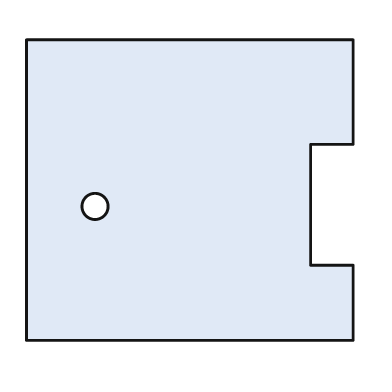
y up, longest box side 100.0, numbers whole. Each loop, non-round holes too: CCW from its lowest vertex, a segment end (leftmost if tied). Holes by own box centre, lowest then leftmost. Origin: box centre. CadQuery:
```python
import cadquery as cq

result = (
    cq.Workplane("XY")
    .moveTo(-50.0, -46.0)
    .lineTo(50.0, -46.0)
    .lineTo(50.0, -23.0)
    .lineTo(37.0, -23.0)
    .lineTo(37.0, 14.0)
    .lineTo(50.0, 14.0)
    .lineTo(50.0, 46.0)
    .lineTo(-50.0, 46.0)
    .close()
    .moveTo(-29.0, -5.0)
    .circle(4.0)
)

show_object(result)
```